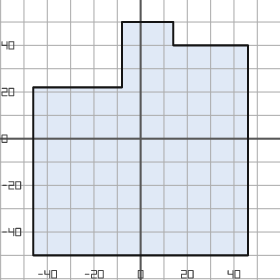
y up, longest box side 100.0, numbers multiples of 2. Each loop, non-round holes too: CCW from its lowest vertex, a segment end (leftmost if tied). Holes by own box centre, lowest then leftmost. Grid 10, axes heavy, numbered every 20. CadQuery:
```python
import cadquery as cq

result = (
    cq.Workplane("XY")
    .moveTo(-46.0, -50.0)
    .lineTo(46.0, -50.0)
    .lineTo(46.0, 40.0)
    .lineTo(14.0, 40.0)
    .lineTo(14.0, 50.0)
    .lineTo(-8.0, 50.0)
    .lineTo(-8.0, 22.0)
    .lineTo(-46.0, 22.0)
    .close()
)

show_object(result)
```